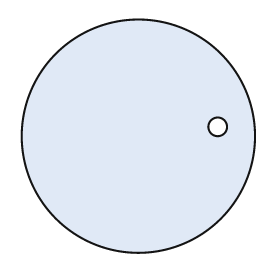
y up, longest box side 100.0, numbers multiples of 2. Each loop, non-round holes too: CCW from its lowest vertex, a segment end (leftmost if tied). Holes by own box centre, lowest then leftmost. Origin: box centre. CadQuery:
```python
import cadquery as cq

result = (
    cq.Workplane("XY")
    .moveTo(0.0, 0.0)
    .circle(50.0)
    .moveTo(34.0, 4.0)
    .circle(4.0)
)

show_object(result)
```